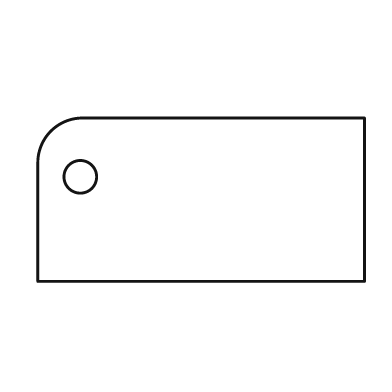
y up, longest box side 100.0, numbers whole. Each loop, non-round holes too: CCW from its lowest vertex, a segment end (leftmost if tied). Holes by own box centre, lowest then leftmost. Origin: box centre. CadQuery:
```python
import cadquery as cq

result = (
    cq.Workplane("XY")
    .moveTo(-50.0, -25.0)
    .lineTo(50.0, -25.0)
    .lineTo(50.0, 25.0)
    .lineTo(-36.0, 25.0)
    .threePointArc((-46.0, 21.0), (-50.0, 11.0))
    .close()
    .moveTo(-37.0, 7.0)
    .circle(5.0)
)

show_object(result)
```